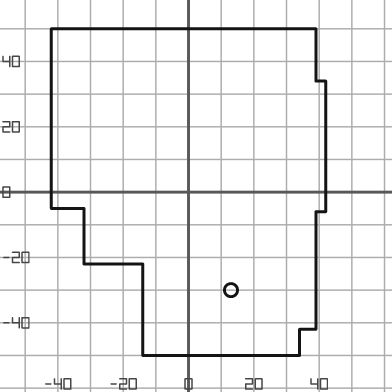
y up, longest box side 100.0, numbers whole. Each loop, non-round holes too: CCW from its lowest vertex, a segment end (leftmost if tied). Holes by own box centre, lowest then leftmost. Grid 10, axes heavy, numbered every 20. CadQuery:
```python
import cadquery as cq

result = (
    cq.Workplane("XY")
    .moveTo(-14.0, -50.0)
    .lineTo(34.0, -50.0)
    .lineTo(34.0, -42.0)
    .lineTo(39.0, -42.0)
    .lineTo(39.0, -6.0)
    .lineTo(42.0, -6.0)
    .lineTo(42.0, 34.0)
    .lineTo(39.0, 34.0)
    .lineTo(39.0, 50.0)
    .lineTo(-42.0, 50.0)
    .lineTo(-42.0, -5.0)
    .lineTo(-32.0, -5.0)
    .lineTo(-32.0, -22.0)
    .lineTo(-14.0, -22.0)
    .close()
    .moveTo(13.0, -30.0)
    .circle(2.0)
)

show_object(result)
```